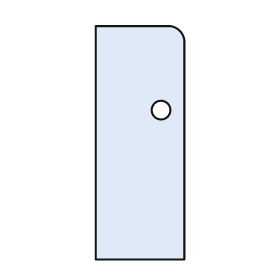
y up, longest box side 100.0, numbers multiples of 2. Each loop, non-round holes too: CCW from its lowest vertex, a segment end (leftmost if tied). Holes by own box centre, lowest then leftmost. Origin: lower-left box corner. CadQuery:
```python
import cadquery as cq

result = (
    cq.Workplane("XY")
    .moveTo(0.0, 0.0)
    .lineTo(38.0, 0.0)
    .lineTo(38.0, 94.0)
    .threePointArc((36.0, 98.0), (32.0, 100.0))
    .lineTo(0.0, 100.0)
    .close()
    .moveTo(28.0, 64.0)
    .circle(4.0)
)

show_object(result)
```